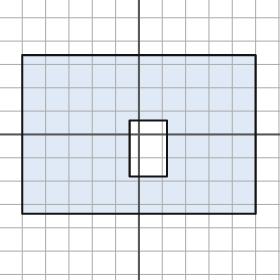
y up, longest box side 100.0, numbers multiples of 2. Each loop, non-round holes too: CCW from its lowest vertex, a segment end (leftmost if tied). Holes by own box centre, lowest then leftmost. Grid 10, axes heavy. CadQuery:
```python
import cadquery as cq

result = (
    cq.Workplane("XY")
    .moveTo(-50.0, -34.0)
    .lineTo(50.0, -34.0)
    .lineTo(50.0, 34.0)
    .lineTo(-50.0, 34.0)
    .close()
    .moveTo(-4.0, -18.0)
    .lineTo(12.0, -18.0)
    .lineTo(12.0, 6.0)
    .lineTo(-4.0, 6.0)
    .close()
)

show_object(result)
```